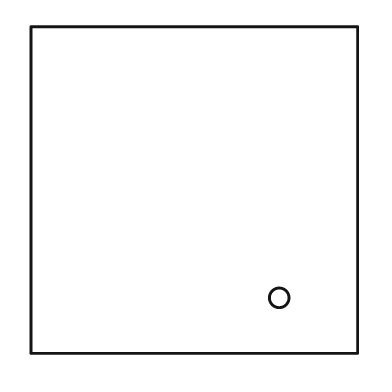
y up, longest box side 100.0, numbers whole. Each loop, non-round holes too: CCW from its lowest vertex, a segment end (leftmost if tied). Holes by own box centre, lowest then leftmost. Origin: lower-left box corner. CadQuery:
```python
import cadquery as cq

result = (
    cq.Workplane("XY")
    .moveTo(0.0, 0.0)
    .lineTo(100.0, 0.0)
    .lineTo(100.0, 100.0)
    .lineTo(0.0, 100.0)
    .close()
    .moveTo(76.0, 17.0)
    .circle(3.0)
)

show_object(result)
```